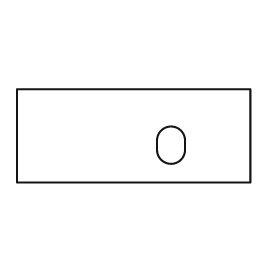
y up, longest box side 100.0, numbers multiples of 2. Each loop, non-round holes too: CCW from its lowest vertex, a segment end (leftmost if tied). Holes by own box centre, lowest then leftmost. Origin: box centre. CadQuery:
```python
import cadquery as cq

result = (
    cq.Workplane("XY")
    .moveTo(-50.0, -20.0)
    .lineTo(50.0, -20.0)
    .lineTo(50.0, 20.0)
    .lineTo(-50.0, 20.0)
    .close()
    .moveTo(10.0, -6.0)
    .threePointArc((16.0, -12.0), (22.0, -6.0))
    .lineTo(22.0, -2.0)
    .threePointArc((16.0, 4.0), (10.0, -2.0))
    .close()
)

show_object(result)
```